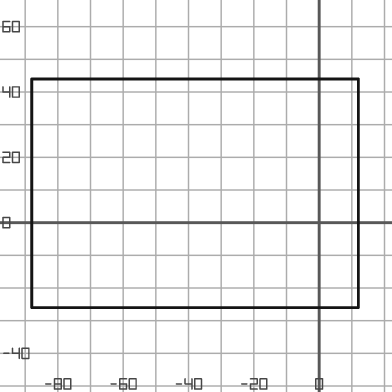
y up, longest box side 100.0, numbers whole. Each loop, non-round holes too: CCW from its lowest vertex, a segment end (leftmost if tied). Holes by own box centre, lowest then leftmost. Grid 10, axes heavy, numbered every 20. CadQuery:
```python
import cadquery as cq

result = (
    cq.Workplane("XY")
    .moveTo(-88.0, -26.0)
    .lineTo(12.0, -26.0)
    .lineTo(12.0, 44.0)
    .lineTo(-88.0, 44.0)
    .close()
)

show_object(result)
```